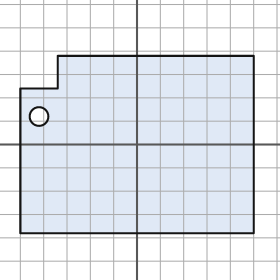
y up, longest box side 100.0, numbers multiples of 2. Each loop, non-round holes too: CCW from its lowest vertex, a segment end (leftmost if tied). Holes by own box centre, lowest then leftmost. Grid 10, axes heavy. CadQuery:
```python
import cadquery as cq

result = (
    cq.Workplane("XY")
    .moveTo(-50.0, -38.0)
    .lineTo(50.0, -38.0)
    .lineTo(50.0, 38.0)
    .lineTo(-34.0, 38.0)
    .lineTo(-34.0, 24.0)
    .lineTo(-50.0, 24.0)
    .close()
    .moveTo(-42.0, 12.0)
    .circle(4.0)
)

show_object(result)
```